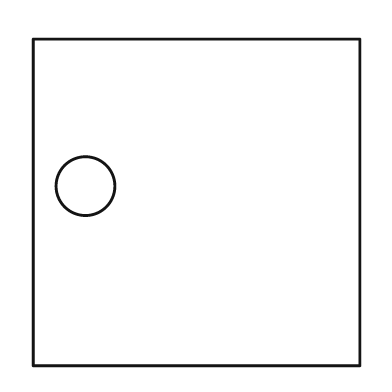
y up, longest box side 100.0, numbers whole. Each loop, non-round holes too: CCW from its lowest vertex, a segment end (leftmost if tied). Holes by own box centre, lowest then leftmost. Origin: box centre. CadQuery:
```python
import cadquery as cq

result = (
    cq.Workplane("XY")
    .moveTo(-50.0, -50.0)
    .lineTo(50.0, -50.0)
    .lineTo(50.0, 50.0)
    .lineTo(-50.0, 50.0)
    .close()
    .moveTo(-34.0, 5.0)
    .circle(9.0)
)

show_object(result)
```